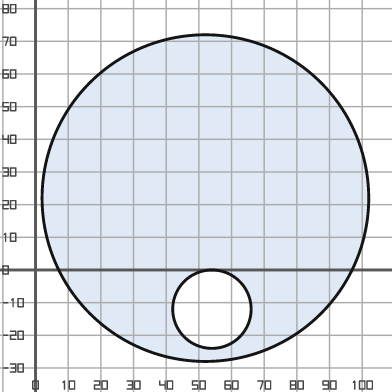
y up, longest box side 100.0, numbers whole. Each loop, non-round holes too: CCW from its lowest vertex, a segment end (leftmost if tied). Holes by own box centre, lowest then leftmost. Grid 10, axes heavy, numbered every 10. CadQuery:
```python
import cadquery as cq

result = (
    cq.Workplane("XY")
    .moveTo(52.0, 22.0)
    .circle(50.0)
    .moveTo(54.0, -12.0)
    .circle(12.0)
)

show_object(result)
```